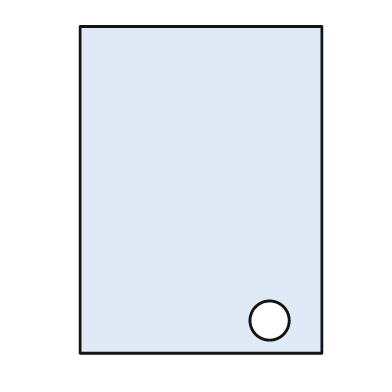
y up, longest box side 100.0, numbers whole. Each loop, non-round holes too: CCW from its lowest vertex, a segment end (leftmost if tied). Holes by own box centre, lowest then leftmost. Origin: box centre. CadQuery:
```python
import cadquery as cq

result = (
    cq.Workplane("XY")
    .moveTo(-37.0, -50.0)
    .lineTo(37.0, -50.0)
    .lineTo(37.0, 50.0)
    .lineTo(-37.0, 50.0)
    .close()
    .moveTo(21.0, -40.0)
    .circle(6.0)
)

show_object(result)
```